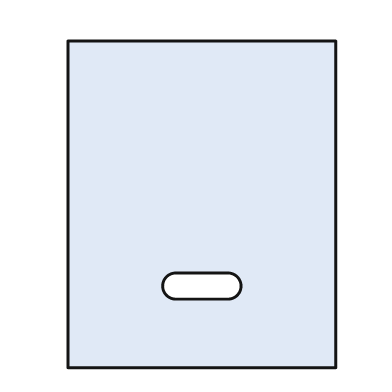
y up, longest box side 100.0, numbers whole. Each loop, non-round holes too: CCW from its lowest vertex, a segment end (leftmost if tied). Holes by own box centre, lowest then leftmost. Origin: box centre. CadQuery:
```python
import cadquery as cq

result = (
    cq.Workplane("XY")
    .moveTo(-41.0, -50.0)
    .lineTo(41.0, -50.0)
    .lineTo(41.0, 50.0)
    .lineTo(-41.0, 50.0)
    .close()
    .moveTo(-8.0, -29.0)
    .lineTo(8.0, -29.0)
    .threePointArc((12.0, -25.0), (8.0, -21.0))
    .lineTo(-8.0, -21.0)
    .threePointArc((-12.0, -25.0), (-8.0, -29.0))
    .close()
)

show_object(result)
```